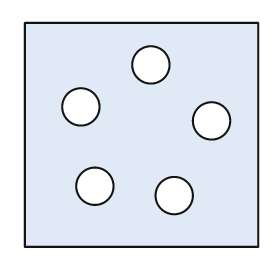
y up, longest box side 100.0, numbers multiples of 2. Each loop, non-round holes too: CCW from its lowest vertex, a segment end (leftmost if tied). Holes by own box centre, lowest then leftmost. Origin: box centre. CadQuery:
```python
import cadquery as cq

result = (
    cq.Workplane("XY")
    .moveTo(-50.0, -48.0)
    .lineTo(50.0, -48.0)
    .lineTo(50.0, 48.0)
    .lineTo(-50.0, 48.0)
    .close()
    .moveTo(14.0, -26.0)
    .circle(8.0)
    .moveTo(-20.0, -22.0)
    .circle(8.0)
    .moveTo(30.0, 6.0)
    .circle(8.0)
    .moveTo(-26.0, 12.0)
    .circle(8.0)
    .moveTo(4.0, 30.0)
    .circle(8.0)
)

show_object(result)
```